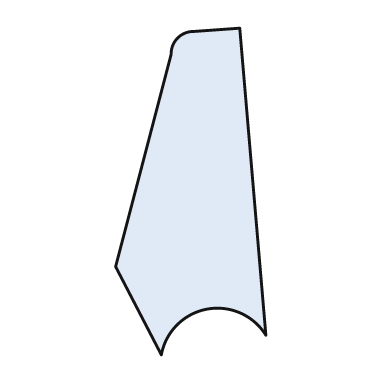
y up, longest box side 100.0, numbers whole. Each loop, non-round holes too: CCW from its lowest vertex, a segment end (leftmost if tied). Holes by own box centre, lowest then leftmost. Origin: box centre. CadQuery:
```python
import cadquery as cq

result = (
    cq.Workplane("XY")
    .moveTo(-9.0, -50.0)
    .threePointArc((5.0, -36.0), (23.0, -44.0))
    .lineTo(15.0, 50.0)
    .lineTo(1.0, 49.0)
    .threePointArc((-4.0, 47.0), (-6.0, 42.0))
    .lineTo(-23.0, -23.0)
    .close()
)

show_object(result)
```